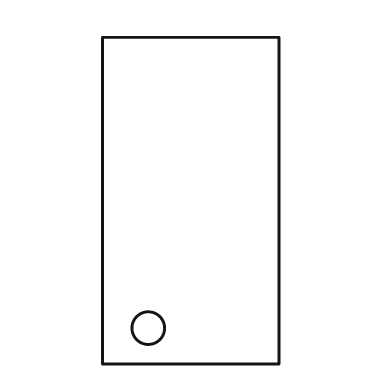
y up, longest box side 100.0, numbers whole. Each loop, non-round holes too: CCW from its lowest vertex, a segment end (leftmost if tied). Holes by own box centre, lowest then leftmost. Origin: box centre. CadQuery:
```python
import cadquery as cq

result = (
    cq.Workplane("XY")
    .moveTo(-27.0, -50.0)
    .lineTo(27.0, -50.0)
    .lineTo(27.0, 50.0)
    .lineTo(-27.0, 50.0)
    .close()
    .moveTo(-13.0, -39.0)
    .circle(5.0)
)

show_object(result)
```